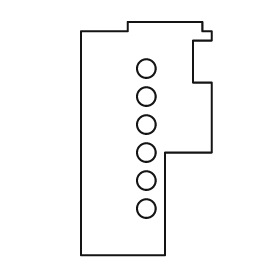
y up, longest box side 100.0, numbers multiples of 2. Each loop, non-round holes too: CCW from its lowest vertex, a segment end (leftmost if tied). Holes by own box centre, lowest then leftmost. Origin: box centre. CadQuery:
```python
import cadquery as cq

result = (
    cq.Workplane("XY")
    .moveTo(-28.0, -50.0)
    .lineTo(8.0, -50.0)
    .lineTo(8.0, -6.0)
    .lineTo(28.0, -6.0)
    .lineTo(28.0, 24.0)
    .lineTo(20.0, 24.0)
    .lineTo(20.0, 42.0)
    .lineTo(28.0, 42.0)
    .lineTo(28.0, 46.0)
    .lineTo(24.0, 46.0)
    .lineTo(24.0, 50.0)
    .lineTo(-8.0, 50.0)
    .lineTo(-8.0, 46.0)
    .lineTo(-28.0, 46.0)
    .close()
    .moveTo(0.0, -30.0)
    .circle(4.0)
    .moveTo(0.0, -18.0)
    .circle(4.0)
    .moveTo(0.0, -6.0)
    .circle(4.0)
    .moveTo(0.0, 6.0)
    .circle(4.0)
    .moveTo(0.0, 18.0)
    .circle(4.0)
    .moveTo(0.0, 30.0)
    .circle(4.0)
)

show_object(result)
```